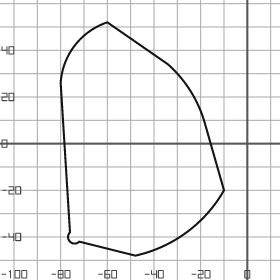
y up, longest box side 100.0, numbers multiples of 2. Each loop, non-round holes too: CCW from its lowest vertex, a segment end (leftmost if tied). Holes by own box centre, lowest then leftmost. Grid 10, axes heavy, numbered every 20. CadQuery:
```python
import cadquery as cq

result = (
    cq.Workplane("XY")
    .moveTo(-48.0, -48.0)
    .threePointArc((-26.0, -38.0), (-10.0, -20.0))
    .lineTo(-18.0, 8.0)
    .threePointArc((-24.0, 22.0), (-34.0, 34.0))
    .lineTo(-60.0, 52.0)
    .threePointArc((-74.0, 42.0), (-80.0, 26.0))
    .lineTo(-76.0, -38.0)
    .threePointArc((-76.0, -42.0), (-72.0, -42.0))
    .close()
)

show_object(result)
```